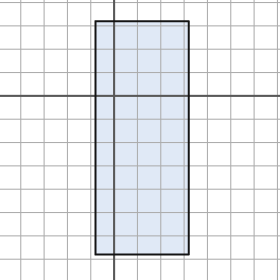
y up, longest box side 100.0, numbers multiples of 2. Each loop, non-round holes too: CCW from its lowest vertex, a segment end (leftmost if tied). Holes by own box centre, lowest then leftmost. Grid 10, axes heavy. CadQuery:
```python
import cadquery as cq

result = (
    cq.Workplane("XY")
    .moveTo(-8.0, -68.0)
    .lineTo(32.0, -68.0)
    .lineTo(32.0, 32.0)
    .lineTo(-8.0, 32.0)
    .close()
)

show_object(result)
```